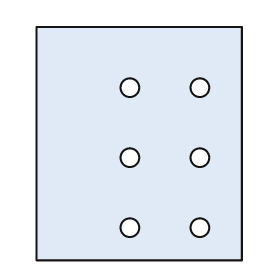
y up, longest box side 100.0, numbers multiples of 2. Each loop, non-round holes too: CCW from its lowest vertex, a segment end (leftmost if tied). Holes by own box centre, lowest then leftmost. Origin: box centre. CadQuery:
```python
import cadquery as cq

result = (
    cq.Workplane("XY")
    .moveTo(-44.0, -50.0)
    .lineTo(44.0, -50.0)
    .lineTo(44.0, 50.0)
    .lineTo(-44.0, 50.0)
    .close()
    .moveTo(-4.0, -36.0)
    .circle(4.0)
    .moveTo(26.0, -36.0)
    .circle(4.0)
    .moveTo(-4.0, -6.0)
    .circle(4.0)
    .moveTo(26.0, -6.0)
    .circle(4.0)
    .moveTo(-4.0, 24.0)
    .circle(4.0)
    .moveTo(26.0, 24.0)
    .circle(4.0)
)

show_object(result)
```